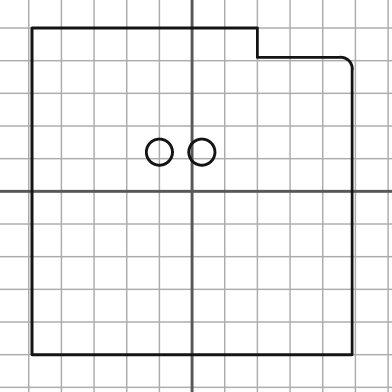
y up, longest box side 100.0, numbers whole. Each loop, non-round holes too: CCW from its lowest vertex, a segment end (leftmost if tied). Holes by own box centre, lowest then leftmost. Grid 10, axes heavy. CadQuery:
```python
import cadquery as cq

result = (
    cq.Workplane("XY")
    .moveTo(-49.0, -50.0)
    .lineTo(49.0, -50.0)
    .lineTo(49.0, 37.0)
    .threePointArc((48.0, 40.0), (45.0, 41.0))
    .lineTo(20.0, 41.0)
    .lineTo(20.0, 50.0)
    .lineTo(-49.0, 50.0)
    .close()
    .moveTo(-10.0, 12.0)
    .circle(4.0)
    .moveTo(3.0, 12.0)
    .circle(4.0)
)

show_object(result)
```